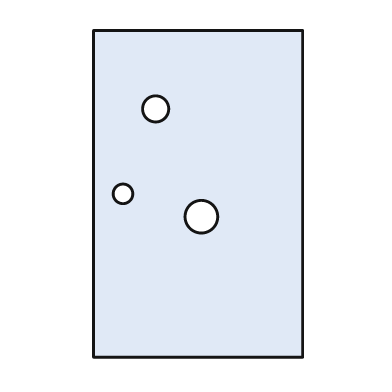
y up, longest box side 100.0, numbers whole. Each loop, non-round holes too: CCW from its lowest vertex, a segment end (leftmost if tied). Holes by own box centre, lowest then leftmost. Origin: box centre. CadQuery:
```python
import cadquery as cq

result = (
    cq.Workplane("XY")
    .moveTo(-32.0, -50.0)
    .lineTo(32.0, -50.0)
    .lineTo(32.0, 50.0)
    .lineTo(-32.0, 50.0)
    .close()
    .moveTo(1.0, -7.0)
    .circle(5.0)
    .moveTo(-23.0, 0.0)
    .circle(3.0)
    .moveTo(-13.0, 26.0)
    .circle(4.0)
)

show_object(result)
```